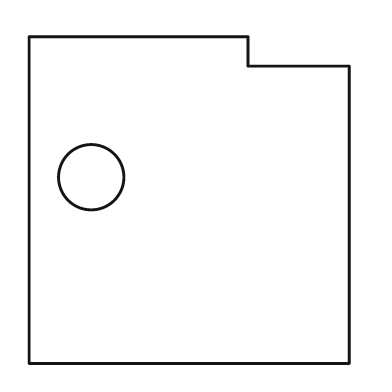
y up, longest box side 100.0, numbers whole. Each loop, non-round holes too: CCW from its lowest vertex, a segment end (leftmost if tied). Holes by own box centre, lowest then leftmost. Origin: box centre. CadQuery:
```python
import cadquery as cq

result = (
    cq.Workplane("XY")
    .moveTo(-49.0, -50.0)
    .lineTo(49.0, -50.0)
    .lineTo(49.0, 41.0)
    .lineTo(18.0, 41.0)
    .lineTo(18.0, 50.0)
    .lineTo(-49.0, 50.0)
    .close()
    .moveTo(-30.0, 7.0)
    .circle(10.0)
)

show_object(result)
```